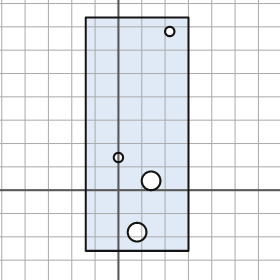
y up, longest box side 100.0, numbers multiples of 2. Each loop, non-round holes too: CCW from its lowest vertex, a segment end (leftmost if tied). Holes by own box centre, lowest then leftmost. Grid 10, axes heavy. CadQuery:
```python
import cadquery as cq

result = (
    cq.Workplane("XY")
    .moveTo(-14.0, -26.0)
    .lineTo(30.0, -26.0)
    .lineTo(30.0, 74.0)
    .lineTo(-14.0, 74.0)
    .close()
    .moveTo(8.0, -18.0)
    .circle(4.0)
    .moveTo(14.0, 4.0)
    .circle(4.0)
    .moveTo(0.0, 14.0)
    .circle(2.0)
    .moveTo(22.0, 68.0)
    .circle(2.0)
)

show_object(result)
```